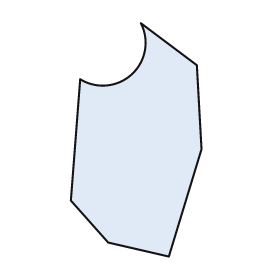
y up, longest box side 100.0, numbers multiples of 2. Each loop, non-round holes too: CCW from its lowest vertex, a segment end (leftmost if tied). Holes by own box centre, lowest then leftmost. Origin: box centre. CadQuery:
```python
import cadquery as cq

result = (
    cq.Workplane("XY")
    .moveTo(14.0, -50.0)
    .lineTo(28.0, -4.0)
    .lineTo(26.0, 32.0)
    .lineTo(2.0, 50.0)
    .threePointArc((-2.0, 28.0), (-24.0, 26.0))
    .lineTo(-28.0, -26.0)
    .lineTo(-12.0, -44.0)
    .close()
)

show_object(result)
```